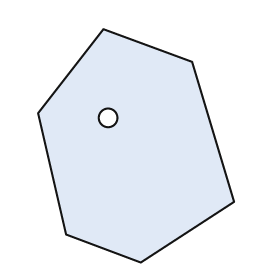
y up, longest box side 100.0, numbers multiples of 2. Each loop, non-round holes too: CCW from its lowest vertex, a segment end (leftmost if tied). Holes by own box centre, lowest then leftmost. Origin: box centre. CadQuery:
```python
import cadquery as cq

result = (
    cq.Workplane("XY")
    .moveTo(2.0, -50.0)
    .lineTo(42.0, -24.0)
    .lineTo(24.0, 36.0)
    .lineTo(-14.0, 50.0)
    .lineTo(-42.0, 14.0)
    .lineTo(-30.0, -38.0)
    .close()
    .moveTo(-12.0, 12.0)
    .circle(4.0)
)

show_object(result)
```